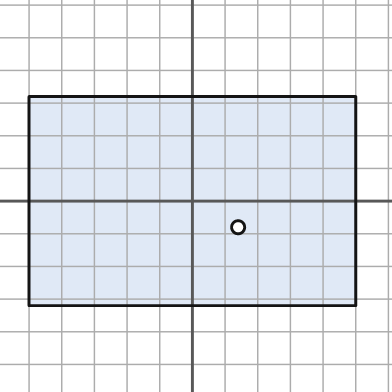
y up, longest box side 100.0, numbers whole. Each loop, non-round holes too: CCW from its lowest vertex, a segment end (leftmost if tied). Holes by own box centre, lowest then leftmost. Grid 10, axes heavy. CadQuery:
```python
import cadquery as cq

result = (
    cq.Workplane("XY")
    .moveTo(-50.0, -32.0)
    .lineTo(50.0, -32.0)
    .lineTo(50.0, 32.0)
    .lineTo(-50.0, 32.0)
    .close()
    .moveTo(14.0, -8.0)
    .circle(2.0)
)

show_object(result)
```